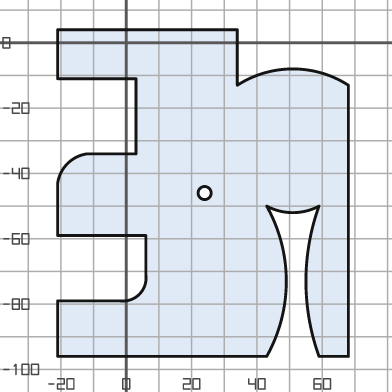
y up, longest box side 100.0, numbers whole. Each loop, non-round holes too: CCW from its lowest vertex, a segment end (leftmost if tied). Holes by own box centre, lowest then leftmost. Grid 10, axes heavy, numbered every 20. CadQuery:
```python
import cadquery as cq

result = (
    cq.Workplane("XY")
    .moveTo(-21.0, -96.0)
    .lineTo(43.0, -96.0)
    .threePointArc((49.0, -73.0), (43.0, -50.0))
    .threePointArc((51.0, -52.0), (59.0, -50.0))
    .threePointArc((55.0, -73.0), (59.0, -96.0))
    .lineTo(68.0, -96.0)
    .lineTo(68.0, -13.0)
    .threePointArc((51.0, -8.0), (34.0, -13.0))
    .lineTo(34.0, 4.0)
    .lineTo(-21.0, 4.0)
    .lineTo(-21.0, -11.0)
    .lineTo(3.0, -11.0)
    .lineTo(3.0, -34.0)
    .lineTo(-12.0, -34.0)
    .threePointArc((-18.0, -37.0), (-21.0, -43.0))
    .lineTo(-21.0, -59.0)
    .lineTo(6.0, -59.0)
    .lineTo(6.0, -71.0)
    .threePointArc((4.0, -77.0), (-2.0, -79.0))
    .lineTo(-21.0, -79.0)
    .close()
    .moveTo(24.0, -46.0)
    .circle(2.0)
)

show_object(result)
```